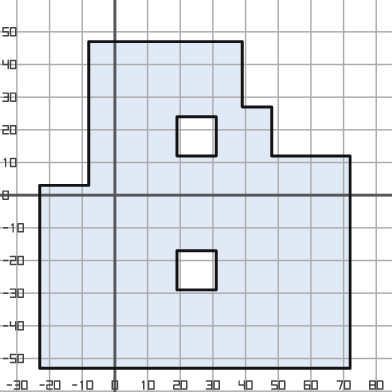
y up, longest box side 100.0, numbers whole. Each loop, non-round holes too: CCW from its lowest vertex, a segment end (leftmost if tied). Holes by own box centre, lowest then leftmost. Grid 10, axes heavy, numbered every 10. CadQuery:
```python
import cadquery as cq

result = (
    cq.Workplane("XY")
    .moveTo(-23.0, -53.0)
    .lineTo(72.0, -53.0)
    .lineTo(72.0, 12.0)
    .lineTo(48.0, 12.0)
    .lineTo(48.0, 27.0)
    .lineTo(39.0, 27.0)
    .lineTo(39.0, 47.0)
    .lineTo(-8.0, 47.0)
    .lineTo(-8.0, 3.0)
    .lineTo(-23.0, 3.0)
    .close()
    .moveTo(19.0, -29.0)
    .lineTo(31.0, -29.0)
    .lineTo(31.0, -17.0)
    .lineTo(19.0, -17.0)
    .close()
    .moveTo(19.0, 12.0)
    .lineTo(31.0, 12.0)
    .lineTo(31.0, 24.0)
    .lineTo(19.0, 24.0)
    .close()
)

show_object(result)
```